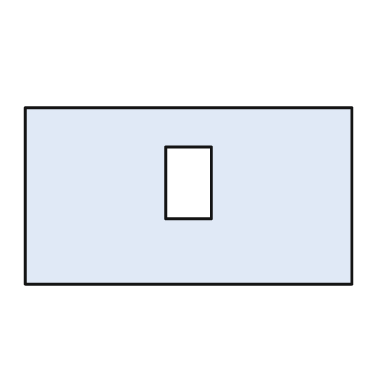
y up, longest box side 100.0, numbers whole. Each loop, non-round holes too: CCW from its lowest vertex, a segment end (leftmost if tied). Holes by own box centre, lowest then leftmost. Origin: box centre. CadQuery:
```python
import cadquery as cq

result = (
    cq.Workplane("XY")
    .moveTo(-50.0, -27.0)
    .lineTo(50.0, -27.0)
    .lineTo(50.0, 27.0)
    .lineTo(-50.0, 27.0)
    .close()
    .moveTo(-7.0, -7.0)
    .lineTo(7.0, -7.0)
    .lineTo(7.0, 15.0)
    .lineTo(-7.0, 15.0)
    .close()
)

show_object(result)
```